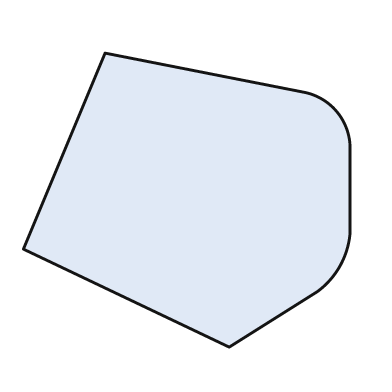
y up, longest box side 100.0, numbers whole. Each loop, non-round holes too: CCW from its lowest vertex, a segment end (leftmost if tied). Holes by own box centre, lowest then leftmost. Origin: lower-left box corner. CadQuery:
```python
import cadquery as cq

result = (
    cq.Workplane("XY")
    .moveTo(63.0, 0.0)
    .lineTo(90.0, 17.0)
    .threePointArc((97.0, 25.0), (100.0, 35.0))
    .lineTo(100.0, 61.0)
    .threePointArc((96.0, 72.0), (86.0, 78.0))
    .lineTo(25.0, 90.0)
    .lineTo(0.0, 30.0)
    .close()
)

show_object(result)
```